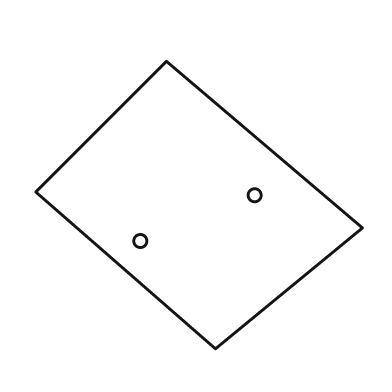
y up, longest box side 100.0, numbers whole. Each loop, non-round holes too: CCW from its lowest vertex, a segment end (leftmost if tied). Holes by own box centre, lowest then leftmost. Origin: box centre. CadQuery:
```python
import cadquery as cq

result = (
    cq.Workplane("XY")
    .moveTo(5.0, -44.0)
    .lineTo(50.0, -7.0)
    .lineTo(-10.0, 44.0)
    .lineTo(-50.0, 4.0)
    .close()
    .moveTo(-18.0, -11.0)
    .circle(2.0)
    .moveTo(17.0, 3.0)
    .circle(2.0)
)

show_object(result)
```